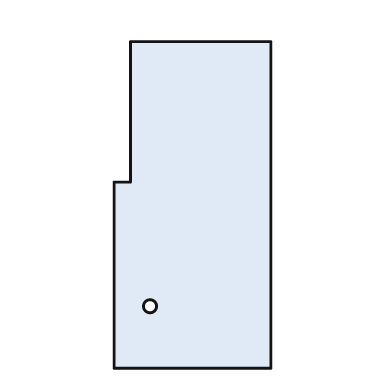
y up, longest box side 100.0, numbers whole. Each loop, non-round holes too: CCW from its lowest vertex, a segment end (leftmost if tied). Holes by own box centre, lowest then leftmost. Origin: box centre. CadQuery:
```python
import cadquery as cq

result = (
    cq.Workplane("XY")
    .moveTo(-24.0, -50.0)
    .lineTo(24.0, -50.0)
    .lineTo(24.0, 50.0)
    .lineTo(-19.0, 50.0)
    .lineTo(-19.0, 7.0)
    .lineTo(-24.0, 7.0)
    .close()
    .moveTo(-13.0, -31.0)
    .circle(2.0)
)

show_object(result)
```